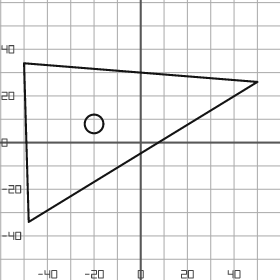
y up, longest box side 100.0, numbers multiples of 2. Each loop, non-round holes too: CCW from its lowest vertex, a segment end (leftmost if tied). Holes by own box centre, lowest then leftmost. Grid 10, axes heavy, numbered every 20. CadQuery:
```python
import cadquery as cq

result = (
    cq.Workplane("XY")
    .moveTo(-48.0, -34.0)
    .lineTo(50.0, 26.0)
    .lineTo(-50.0, 34.0)
    .close()
    .moveTo(-20.0, 8.0)
    .circle(4.0)
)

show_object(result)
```